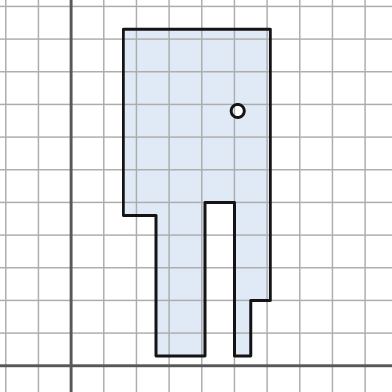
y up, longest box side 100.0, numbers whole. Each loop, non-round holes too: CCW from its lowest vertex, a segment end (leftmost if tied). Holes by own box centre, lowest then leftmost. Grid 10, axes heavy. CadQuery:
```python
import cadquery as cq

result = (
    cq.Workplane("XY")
    .moveTo(26.0, 3.0)
    .lineTo(41.0, 3.0)
    .lineTo(41.0, 50.0)
    .lineTo(50.0, 50.0)
    .lineTo(50.0, 3.0)
    .lineTo(55.0, 3.0)
    .lineTo(55.0, 20.0)
    .lineTo(61.0, 20.0)
    .lineTo(61.0, 103.0)
    .lineTo(16.0, 103.0)
    .lineTo(16.0, 46.0)
    .lineTo(26.0, 46.0)
    .close()
    .moveTo(51.0, 78.0)
    .circle(2.0)
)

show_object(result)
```